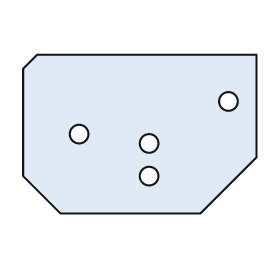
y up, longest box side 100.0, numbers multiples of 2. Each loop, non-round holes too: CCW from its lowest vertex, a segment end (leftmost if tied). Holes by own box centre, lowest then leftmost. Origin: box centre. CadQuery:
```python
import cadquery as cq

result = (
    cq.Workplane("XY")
    .moveTo(-34.0, -34.0)
    .lineTo(26.0, -34.0)
    .lineTo(50.0, -10.0)
    .lineTo(50.0, 34.0)
    .lineTo(-44.0, 34.0)
    .lineTo(-50.0, 28.0)
    .lineTo(-50.0, -18.0)
    .close()
    .moveTo(4.0, -18.0)
    .circle(4.0)
    .moveTo(4.0, -4.0)
    .circle(4.0)
    .moveTo(-26.0, 0.0)
    .circle(4.0)
    .moveTo(38.0, 14.0)
    .circle(4.0)
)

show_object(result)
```